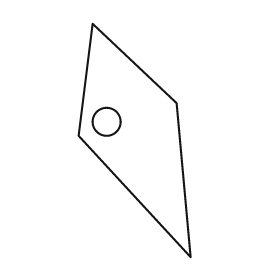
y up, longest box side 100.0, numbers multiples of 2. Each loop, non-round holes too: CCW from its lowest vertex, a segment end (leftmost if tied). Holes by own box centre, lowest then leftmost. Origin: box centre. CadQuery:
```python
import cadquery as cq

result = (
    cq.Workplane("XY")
    .moveTo(24.0, -50.0)
    .lineTo(18.0, 16.0)
    .lineTo(-18.0, 50.0)
    .lineTo(-24.0, 2.0)
    .close()
    .moveTo(-12.0, 8.0)
    .circle(6.0)
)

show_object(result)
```